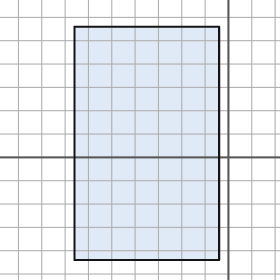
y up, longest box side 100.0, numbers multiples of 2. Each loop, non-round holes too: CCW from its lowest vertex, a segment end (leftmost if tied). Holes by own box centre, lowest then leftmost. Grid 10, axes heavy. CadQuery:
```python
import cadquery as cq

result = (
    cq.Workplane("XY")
    .moveTo(-66.0, -44.0)
    .lineTo(-4.0, -44.0)
    .lineTo(-4.0, 56.0)
    .lineTo(-66.0, 56.0)
    .close()
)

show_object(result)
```